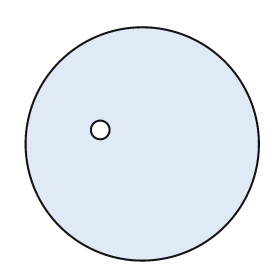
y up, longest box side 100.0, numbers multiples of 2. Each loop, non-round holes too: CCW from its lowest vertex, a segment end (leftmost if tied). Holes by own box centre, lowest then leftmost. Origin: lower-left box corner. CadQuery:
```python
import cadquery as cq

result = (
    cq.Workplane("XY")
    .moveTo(50.0, 50.0)
    .circle(50.0)
    .moveTo(32.0, 56.0)
    .circle(4.0)
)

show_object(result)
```